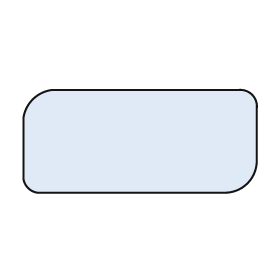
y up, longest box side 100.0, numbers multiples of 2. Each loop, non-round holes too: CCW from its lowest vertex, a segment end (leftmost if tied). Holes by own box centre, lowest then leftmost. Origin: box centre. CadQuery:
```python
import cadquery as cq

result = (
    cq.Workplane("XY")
    .moveTo(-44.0, -22.0)
    .lineTo(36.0, -22.0)
    .threePointArc((46.0, -18.0), (50.0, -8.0))
    .lineTo(50.0, 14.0)
    .threePointArc((48.0, 20.0), (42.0, 22.0))
    .lineTo(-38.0, 22.0)
    .threePointArc((-46.0, 18.0), (-50.0, 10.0))
    .lineTo(-50.0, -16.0)
    .threePointArc((-48.0, -20.0), (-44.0, -22.0))
    .close()
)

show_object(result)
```